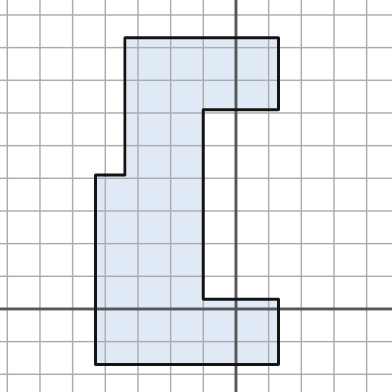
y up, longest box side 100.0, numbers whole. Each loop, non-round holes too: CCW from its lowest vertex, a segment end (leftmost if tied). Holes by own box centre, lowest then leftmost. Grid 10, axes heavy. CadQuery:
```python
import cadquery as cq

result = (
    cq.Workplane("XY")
    .moveTo(-43.0, -17.0)
    .lineTo(13.0, -17.0)
    .lineTo(13.0, 3.0)
    .lineTo(-10.0, 3.0)
    .lineTo(-10.0, 61.0)
    .lineTo(13.0, 61.0)
    .lineTo(13.0, 83.0)
    .lineTo(-34.0, 83.0)
    .lineTo(-34.0, 41.0)
    .lineTo(-43.0, 41.0)
    .close()
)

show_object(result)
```